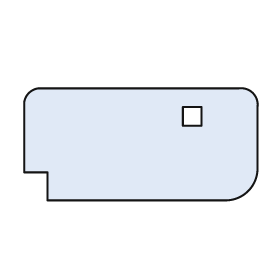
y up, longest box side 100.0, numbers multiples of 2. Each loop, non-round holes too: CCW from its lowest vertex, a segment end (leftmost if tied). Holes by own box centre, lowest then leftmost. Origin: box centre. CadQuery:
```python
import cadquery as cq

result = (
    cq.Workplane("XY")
    .moveTo(-40.0, -24.0)
    .lineTo(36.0, -24.0)
    .threePointArc((46.0, -20.0), (50.0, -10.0))
    .lineTo(50.0, 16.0)
    .threePointArc((48.0, 22.0), (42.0, 24.0))
    .lineTo(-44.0, 24.0)
    .threePointArc((-48.0, 22.0), (-50.0, 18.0))
    .lineTo(-50.0, -12.0)
    .lineTo(-40.0, -12.0)
    .close()
    .moveTo(18.0, 8.0)
    .lineTo(26.0, 8.0)
    .lineTo(26.0, 16.0)
    .lineTo(18.0, 16.0)
    .close()
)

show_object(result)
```